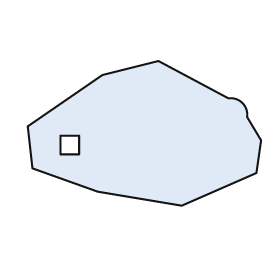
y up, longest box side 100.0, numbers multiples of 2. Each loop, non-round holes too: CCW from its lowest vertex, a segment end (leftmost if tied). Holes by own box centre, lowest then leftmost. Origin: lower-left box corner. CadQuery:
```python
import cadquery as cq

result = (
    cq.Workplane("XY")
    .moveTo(66.0, 0.0)
    .lineTo(98.0, 14.0)
    .lineTo(100.0, 28.0)
    .lineTo(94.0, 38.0)
    .threePointArc((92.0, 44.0), (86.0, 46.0))
    .lineTo(56.0, 62.0)
    .lineTo(32.0, 56.0)
    .lineTo(0.0, 34.0)
    .lineTo(2.0, 16.0)
    .lineTo(30.0, 6.0)
    .close()
    .moveTo(14.0, 22.0)
    .lineTo(22.0, 22.0)
    .lineTo(22.0, 30.0)
    .lineTo(14.0, 30.0)
    .close()
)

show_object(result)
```